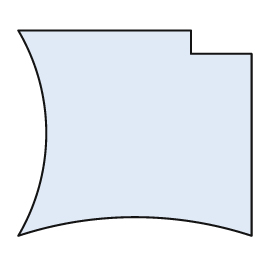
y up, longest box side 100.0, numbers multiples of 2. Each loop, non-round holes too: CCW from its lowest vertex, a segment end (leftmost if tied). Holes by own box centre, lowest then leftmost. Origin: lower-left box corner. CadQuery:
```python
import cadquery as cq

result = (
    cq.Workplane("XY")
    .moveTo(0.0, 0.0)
    .threePointArc((50.0, 8.0), (100.0, 0.0))
    .lineTo(100.0, 78.0)
    .lineTo(74.0, 78.0)
    .lineTo(74.0, 88.0)
    .lineTo(0.0, 88.0)
    .threePointArc((12.0, 44.0), (0.0, 0.0))
    .close()
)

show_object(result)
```